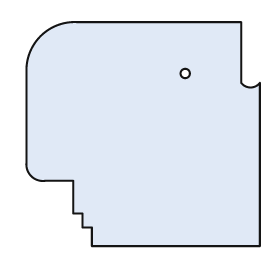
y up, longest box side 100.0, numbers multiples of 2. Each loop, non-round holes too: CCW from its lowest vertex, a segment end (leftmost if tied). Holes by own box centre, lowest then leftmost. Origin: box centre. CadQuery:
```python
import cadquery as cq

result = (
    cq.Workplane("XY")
    .moveTo(-22.0, -48.0)
    .lineTo(50.0, -48.0)
    .lineTo(50.0, 22.0)
    .threePointArc((46.0, 20.0), (42.0, 22.0))
    .lineTo(42.0, 48.0)
    .lineTo(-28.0, 48.0)
    .threePointArc((-44.0, 42.0), (-50.0, 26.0))
    .lineTo(-50.0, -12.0)
    .threePointArc((-48.0, -18.0), (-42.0, -20.0))
    .lineTo(-30.0, -20.0)
    .lineTo(-30.0, -34.0)
    .lineTo(-26.0, -34.0)
    .lineTo(-26.0, -40.0)
    .lineTo(-22.0, -40.0)
    .close()
    .moveTo(18.0, 26.0)
    .circle(2.0)
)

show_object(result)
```